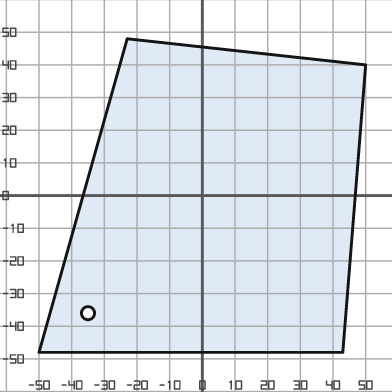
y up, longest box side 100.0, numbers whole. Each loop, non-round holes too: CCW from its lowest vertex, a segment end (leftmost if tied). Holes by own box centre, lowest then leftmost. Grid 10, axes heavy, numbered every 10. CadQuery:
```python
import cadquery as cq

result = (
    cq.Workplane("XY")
    .moveTo(-50.0, -48.0)
    .lineTo(43.0, -48.0)
    .lineTo(50.0, 40.0)
    .lineTo(-23.0, 48.0)
    .close()
    .moveTo(-35.0, -36.0)
    .circle(2.0)
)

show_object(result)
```